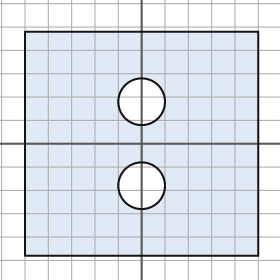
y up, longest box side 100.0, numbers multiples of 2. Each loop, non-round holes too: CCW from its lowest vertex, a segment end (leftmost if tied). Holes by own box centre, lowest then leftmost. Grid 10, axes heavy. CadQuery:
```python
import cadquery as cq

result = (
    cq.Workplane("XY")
    .moveTo(-50.0, -48.0)
    .lineTo(50.0, -48.0)
    .lineTo(50.0, 48.0)
    .lineTo(-50.0, 48.0)
    .close()
    .moveTo(0.0, -18.0)
    .circle(10.0)
    .moveTo(0.0, 18.0)
    .circle(10.0)
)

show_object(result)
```